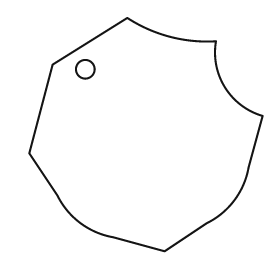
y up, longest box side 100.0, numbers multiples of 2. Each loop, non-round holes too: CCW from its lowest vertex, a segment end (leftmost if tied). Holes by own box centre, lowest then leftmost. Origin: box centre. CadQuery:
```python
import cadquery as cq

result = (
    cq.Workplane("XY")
    .moveTo(8.0, -50.0)
    .lineTo(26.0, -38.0)
    .threePointArc((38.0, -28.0), (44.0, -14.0))
    .lineTo(50.0, 8.0)
    .threePointArc((34.0, 20.0), (30.0, 40.0))
    .threePointArc((10.0, 42.0), (-8.0, 50.0))
    .lineTo(-40.0, 30.0)
    .lineTo(-50.0, -8.0)
    .lineTo(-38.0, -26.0)
    .threePointArc((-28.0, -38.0), (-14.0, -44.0))
    .close()
    .moveTo(-26.0, 28.0)
    .circle(4.0)
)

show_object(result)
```